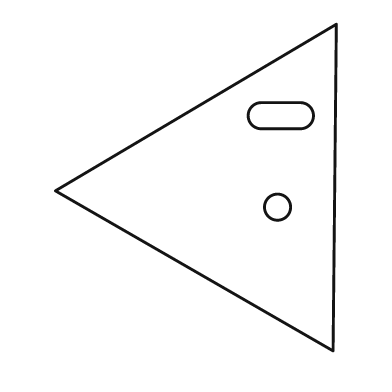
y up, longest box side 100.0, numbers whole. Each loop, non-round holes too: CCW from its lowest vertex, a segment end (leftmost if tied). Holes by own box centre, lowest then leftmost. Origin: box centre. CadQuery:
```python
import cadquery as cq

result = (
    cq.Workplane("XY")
    .moveTo(42.0, -50.0)
    .lineTo(43.0, 50.0)
    .lineTo(-43.0, -1.0)
    .close()
    .moveTo(25.0, -6.0)
    .circle(4.0)
    .moveTo(20.0, 18.0)
    .lineTo(32.0, 18.0)
    .threePointArc((36.0, 22.0), (32.0, 26.0))
    .lineTo(20.0, 26.0)
    .threePointArc((16.0, 22.0), (20.0, 18.0))
    .close()
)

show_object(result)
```